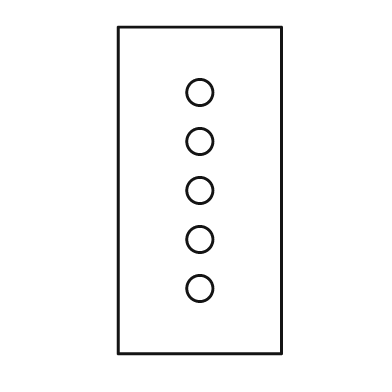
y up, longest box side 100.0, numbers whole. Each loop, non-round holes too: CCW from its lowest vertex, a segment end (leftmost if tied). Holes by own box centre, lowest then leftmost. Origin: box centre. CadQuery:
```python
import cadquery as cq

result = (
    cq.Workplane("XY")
    .moveTo(-25.0, -50.0)
    .lineTo(25.0, -50.0)
    .lineTo(25.0, 50.0)
    .lineTo(-25.0, 50.0)
    .close()
    .moveTo(0.0, -30.0)
    .circle(4.0)
    .moveTo(0.0, -15.0)
    .circle(4.0)
    .moveTo(0.0, 0.0)
    .circle(4.0)
    .moveTo(0.0, 15.0)
    .circle(4.0)
    .moveTo(0.0, 30.0)
    .circle(4.0)
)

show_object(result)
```